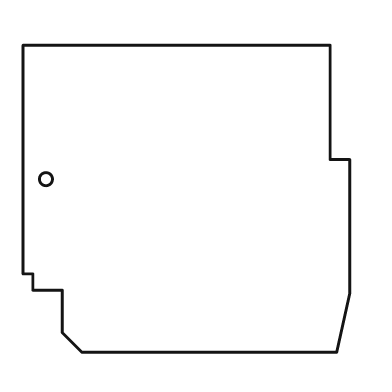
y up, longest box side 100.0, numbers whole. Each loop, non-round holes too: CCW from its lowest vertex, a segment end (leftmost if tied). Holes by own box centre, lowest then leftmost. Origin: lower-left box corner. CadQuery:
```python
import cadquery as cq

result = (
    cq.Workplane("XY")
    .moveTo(18.0, 0.0)
    .lineTo(96.0, 0.0)
    .lineTo(100.0, 18.0)
    .lineTo(100.0, 59.0)
    .lineTo(94.0, 59.0)
    .lineTo(94.0, 94.0)
    .lineTo(0.0, 94.0)
    .lineTo(0.0, 24.0)
    .lineTo(3.0, 24.0)
    .lineTo(3.0, 19.0)
    .lineTo(12.0, 19.0)
    .lineTo(12.0, 6.0)
    .close()
    .moveTo(7.0, 53.0)
    .circle(2.0)
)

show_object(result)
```